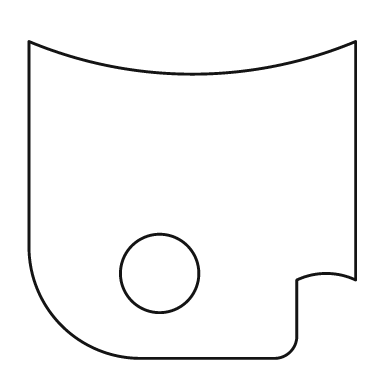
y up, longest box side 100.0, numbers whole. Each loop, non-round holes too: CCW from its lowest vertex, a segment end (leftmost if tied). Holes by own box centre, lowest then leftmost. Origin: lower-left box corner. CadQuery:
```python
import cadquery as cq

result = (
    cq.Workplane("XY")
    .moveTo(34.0, 0.0)
    .lineTo(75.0, 0.0)
    .threePointArc((80.0, 2.0), (82.0, 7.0))
    .lineTo(82.0, 24.0)
    .threePointArc((91.0, 26.0), (100.0, 24.0))
    .lineTo(100.0, 97.0)
    .threePointArc((50.0, 87.0), (0.0, 97.0))
    .lineTo(0.0, 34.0)
    .threePointArc((10.0, 10.0), (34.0, 0.0))
    .close()
    .moveTo(40.0, 26.0)
    .circle(12.0)
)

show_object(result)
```